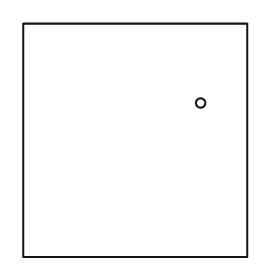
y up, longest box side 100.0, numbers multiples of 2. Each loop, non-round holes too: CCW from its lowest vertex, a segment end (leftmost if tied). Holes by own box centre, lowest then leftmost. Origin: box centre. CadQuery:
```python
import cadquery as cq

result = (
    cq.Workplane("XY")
    .moveTo(-48.0, -50.0)
    .lineTo(48.0, -50.0)
    .lineTo(48.0, 50.0)
    .lineTo(-48.0, 50.0)
    .close()
    .moveTo(28.0, 16.0)
    .circle(2.0)
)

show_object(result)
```